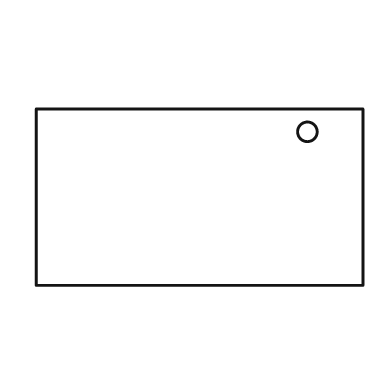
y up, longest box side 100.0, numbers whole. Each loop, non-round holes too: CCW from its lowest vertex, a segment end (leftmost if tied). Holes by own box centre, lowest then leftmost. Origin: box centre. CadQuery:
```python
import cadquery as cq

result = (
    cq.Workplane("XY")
    .moveTo(-50.0, -27.0)
    .lineTo(50.0, -27.0)
    .lineTo(50.0, 27.0)
    .lineTo(-50.0, 27.0)
    .close()
    .moveTo(33.0, 20.0)
    .circle(3.0)
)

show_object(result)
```